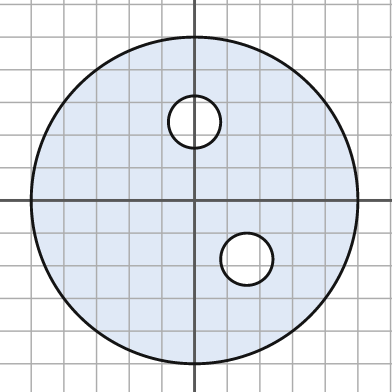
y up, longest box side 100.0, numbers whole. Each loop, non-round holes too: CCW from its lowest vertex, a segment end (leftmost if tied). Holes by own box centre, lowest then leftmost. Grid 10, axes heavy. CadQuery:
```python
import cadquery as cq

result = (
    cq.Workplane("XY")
    .moveTo(0.0, 0.0)
    .circle(50.0)
    .moveTo(16.0, -18.0)
    .circle(8.0)
    .moveTo(0.0, 24.0)
    .circle(8.0)
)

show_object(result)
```